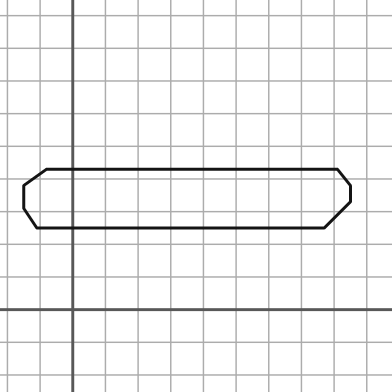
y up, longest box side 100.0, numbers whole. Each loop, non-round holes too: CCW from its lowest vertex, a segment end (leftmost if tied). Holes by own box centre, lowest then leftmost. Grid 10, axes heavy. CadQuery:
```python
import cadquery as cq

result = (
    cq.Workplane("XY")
    .moveTo(-11.0, 25.0)
    .lineTo(77.0, 25.0)
    .lineTo(85.0, 33.0)
    .lineTo(85.0, 38.0)
    .lineTo(81.0, 43.0)
    .lineTo(-8.0, 43.0)
    .lineTo(-15.0, 38.0)
    .lineTo(-15.0, 31.0)
    .close()
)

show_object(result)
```